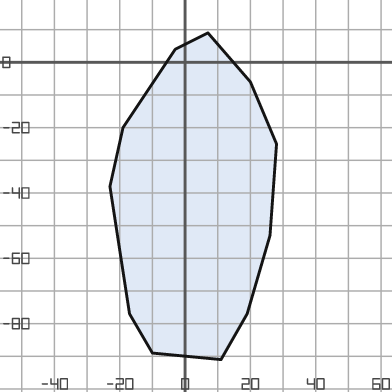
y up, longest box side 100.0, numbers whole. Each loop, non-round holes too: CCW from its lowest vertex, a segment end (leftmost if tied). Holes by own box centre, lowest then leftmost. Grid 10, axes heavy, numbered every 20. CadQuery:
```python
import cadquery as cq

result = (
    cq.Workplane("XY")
    .moveTo(11.0, -91.0)
    .lineTo(19.0, -77.0)
    .lineTo(26.0, -53.0)
    .lineTo(28.0, -25.0)
    .lineTo(20.0, -6.0)
    .lineTo(7.0, 9.0)
    .lineTo(-3.0, 4.0)
    .lineTo(-19.0, -20.0)
    .lineTo(-23.0, -38.0)
    .lineTo(-17.0, -77.0)
    .lineTo(-10.0, -89.0)
    .close()
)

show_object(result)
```